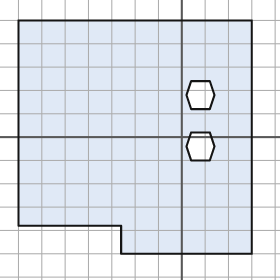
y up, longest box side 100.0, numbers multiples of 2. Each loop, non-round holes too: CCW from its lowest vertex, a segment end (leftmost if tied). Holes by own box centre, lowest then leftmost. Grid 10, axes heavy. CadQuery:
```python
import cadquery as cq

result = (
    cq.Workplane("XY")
    .moveTo(-26.0, -50.0)
    .lineTo(30.0, -50.0)
    .lineTo(30.0, 50.0)
    .lineTo(-70.0, 50.0)
    .lineTo(-70.0, -38.0)
    .lineTo(-26.0, -38.0)
    .close()
    .moveTo(4.0, -10.0)
    .lineTo(12.0, -10.0)
    .lineTo(14.0, -4.0)
    .lineTo(12.0, 2.0)
    .lineTo(4.0, 2.0)
    .lineTo(2.0, -4.0)
    .close()
    .moveTo(4.0, 12.0)
    .lineTo(12.0, 12.0)
    .lineTo(14.0, 18.0)
    .lineTo(12.0, 24.0)
    .lineTo(4.0, 24.0)
    .lineTo(2.0, 18.0)
    .close()
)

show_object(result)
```